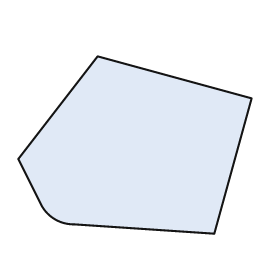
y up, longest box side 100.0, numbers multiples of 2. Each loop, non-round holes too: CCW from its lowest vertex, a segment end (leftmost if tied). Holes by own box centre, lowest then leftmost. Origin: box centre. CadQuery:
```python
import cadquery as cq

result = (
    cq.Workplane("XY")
    .moveTo(34.0, -38.0)
    .lineTo(50.0, 20.0)
    .lineTo(-16.0, 38.0)
    .lineTo(-50.0, -6.0)
    .lineTo(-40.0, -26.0)
    .threePointArc((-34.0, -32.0), (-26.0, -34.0))
    .close()
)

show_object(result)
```